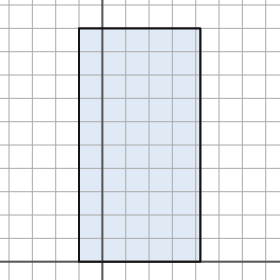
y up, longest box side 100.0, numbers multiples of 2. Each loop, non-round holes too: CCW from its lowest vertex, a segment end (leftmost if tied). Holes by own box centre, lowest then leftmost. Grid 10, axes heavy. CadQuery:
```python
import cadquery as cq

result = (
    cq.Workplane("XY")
    .moveTo(-10.0, 0.0)
    .lineTo(42.0, 0.0)
    .lineTo(42.0, 100.0)
    .lineTo(-10.0, 100.0)
    .close()
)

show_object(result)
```